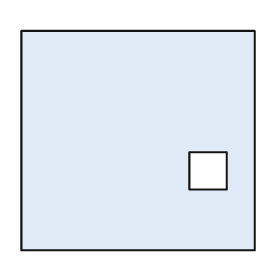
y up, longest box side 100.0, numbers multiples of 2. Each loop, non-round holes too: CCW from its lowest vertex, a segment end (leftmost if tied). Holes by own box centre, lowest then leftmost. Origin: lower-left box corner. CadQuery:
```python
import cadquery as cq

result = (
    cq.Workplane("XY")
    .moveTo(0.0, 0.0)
    .lineTo(100.0, 0.0)
    .lineTo(100.0, 94.0)
    .lineTo(0.0, 94.0)
    .close()
    .moveTo(72.0, 26.0)
    .lineTo(88.0, 26.0)
    .lineTo(88.0, 42.0)
    .lineTo(72.0, 42.0)
    .close()
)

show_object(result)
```